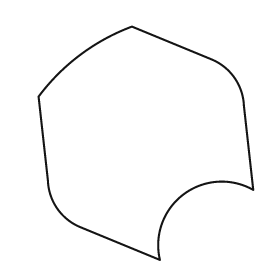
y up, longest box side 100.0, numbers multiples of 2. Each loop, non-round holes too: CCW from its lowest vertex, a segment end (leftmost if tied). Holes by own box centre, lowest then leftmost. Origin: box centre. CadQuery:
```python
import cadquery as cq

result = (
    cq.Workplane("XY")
    .moveTo(6.0, -50.0)
    .threePointArc((16.0, -22.0), (46.0, -20.0))
    .lineTo(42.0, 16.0)
    .threePointArc((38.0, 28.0), (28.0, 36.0))
    .lineTo(-6.0, 50.0)
    .threePointArc((-28.0, 38.0), (-46.0, 20.0))
    .lineTo(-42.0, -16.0)
    .threePointArc((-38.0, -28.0), (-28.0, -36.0))
    .close()
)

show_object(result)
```